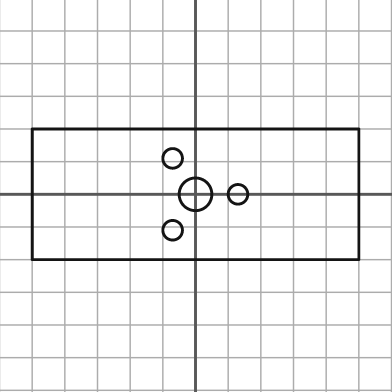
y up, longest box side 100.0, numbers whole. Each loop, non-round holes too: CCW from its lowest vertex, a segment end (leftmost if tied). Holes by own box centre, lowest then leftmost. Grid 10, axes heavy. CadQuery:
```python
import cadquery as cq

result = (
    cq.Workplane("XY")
    .moveTo(-50.0, -20.0)
    .lineTo(50.0, -20.0)
    .lineTo(50.0, 20.0)
    .lineTo(-50.0, 20.0)
    .close()
    .moveTo(-7.0, -11.0)
    .circle(3.0)
    .moveTo(0.0, 0.0)
    .circle(5.0)
    .moveTo(13.0, 0.0)
    .circle(3.0)
    .moveTo(-7.0, 11.0)
    .circle(3.0)
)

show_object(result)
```